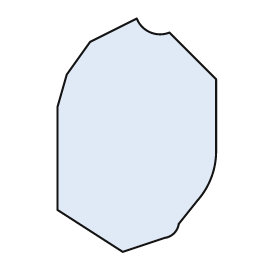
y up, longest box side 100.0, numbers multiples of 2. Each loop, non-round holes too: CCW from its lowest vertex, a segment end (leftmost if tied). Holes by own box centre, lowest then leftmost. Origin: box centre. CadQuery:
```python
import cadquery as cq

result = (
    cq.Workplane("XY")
    .moveTo(-6.0, -50.0)
    .lineTo(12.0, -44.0)
    .threePointArc((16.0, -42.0), (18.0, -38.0))
    .lineTo(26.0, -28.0)
    .threePointArc((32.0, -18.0), (34.0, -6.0))
    .lineTo(34.0, 24.0)
    .lineTo(14.0, 44.0)
    .threePointArc((6.0, 44.0), (0.0, 50.0))
    .lineTo(-20.0, 40.0)
    .lineTo(-30.0, 26.0)
    .lineTo(-34.0, 12.0)
    .lineTo(-34.0, -32.0)
    .close()
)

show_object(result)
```